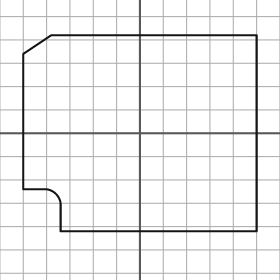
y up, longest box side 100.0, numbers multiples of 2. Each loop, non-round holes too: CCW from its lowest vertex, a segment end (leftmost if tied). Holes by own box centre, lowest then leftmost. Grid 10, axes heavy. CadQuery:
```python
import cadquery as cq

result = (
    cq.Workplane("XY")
    .moveTo(-34.0, -42.0)
    .lineTo(50.0, -42.0)
    .lineTo(50.0, 42.0)
    .lineTo(-38.0, 42.0)
    .lineTo(-50.0, 34.0)
    .lineTo(-50.0, -24.0)
    .lineTo(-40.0, -24.0)
    .threePointArc((-36.0, -26.0), (-34.0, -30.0))
    .close()
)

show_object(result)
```